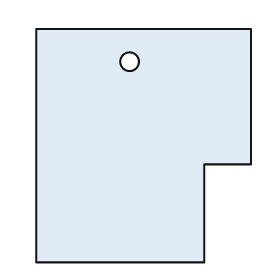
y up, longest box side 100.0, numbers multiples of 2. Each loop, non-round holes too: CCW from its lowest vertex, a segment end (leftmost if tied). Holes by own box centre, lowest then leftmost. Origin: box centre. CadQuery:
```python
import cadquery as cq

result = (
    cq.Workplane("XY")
    .moveTo(-46.0, -50.0)
    .lineTo(26.0, -50.0)
    .lineTo(26.0, -8.0)
    .lineTo(46.0, -8.0)
    .lineTo(46.0, 50.0)
    .lineTo(-46.0, 50.0)
    .close()
    .moveTo(-6.0, 36.0)
    .circle(4.0)
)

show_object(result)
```